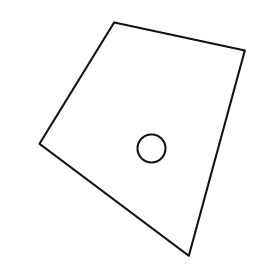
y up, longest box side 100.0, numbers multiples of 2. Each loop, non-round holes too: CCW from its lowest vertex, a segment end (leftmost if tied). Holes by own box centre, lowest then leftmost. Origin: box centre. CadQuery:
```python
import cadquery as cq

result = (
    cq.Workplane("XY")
    .moveTo(20.0, -50.0)
    .lineTo(44.0, 38.0)
    .lineTo(-12.0, 50.0)
    .lineTo(-44.0, -2.0)
    .close()
    .moveTo(4.0, -4.0)
    .circle(6.0)
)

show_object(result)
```